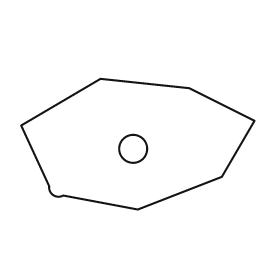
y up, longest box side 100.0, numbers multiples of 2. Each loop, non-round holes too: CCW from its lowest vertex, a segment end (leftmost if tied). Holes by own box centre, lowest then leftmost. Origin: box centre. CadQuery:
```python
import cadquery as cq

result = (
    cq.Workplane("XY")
    .moveTo(0.0, -28.0)
    .lineTo(36.0, -14.0)
    .lineTo(50.0, 10.0)
    .lineTo(22.0, 24.0)
    .lineTo(-16.0, 28.0)
    .lineTo(-50.0, 8.0)
    .lineTo(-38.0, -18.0)
    .threePointArc((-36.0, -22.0), (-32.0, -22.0))
    .close()
    .moveTo(-2.0, -2.0)
    .circle(6.0)
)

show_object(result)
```